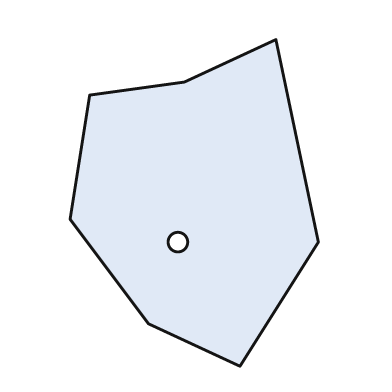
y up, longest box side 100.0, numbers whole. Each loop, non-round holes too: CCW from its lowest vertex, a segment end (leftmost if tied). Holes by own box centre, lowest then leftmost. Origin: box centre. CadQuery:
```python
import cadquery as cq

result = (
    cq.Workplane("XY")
    .moveTo(14.0, -50.0)
    .lineTo(38.0, -12.0)
    .lineTo(25.0, 50.0)
    .lineTo(-3.0, 37.0)
    .lineTo(-32.0, 33.0)
    .lineTo(-38.0, -5.0)
    .lineTo(-14.0, -37.0)
    .close()
    .moveTo(-5.0, -12.0)
    .circle(3.0)
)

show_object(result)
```